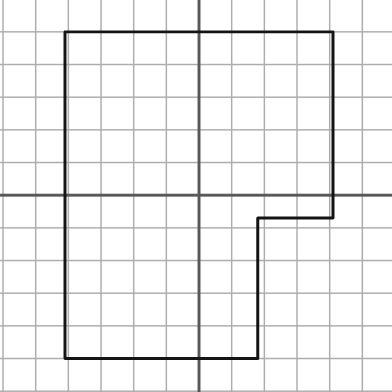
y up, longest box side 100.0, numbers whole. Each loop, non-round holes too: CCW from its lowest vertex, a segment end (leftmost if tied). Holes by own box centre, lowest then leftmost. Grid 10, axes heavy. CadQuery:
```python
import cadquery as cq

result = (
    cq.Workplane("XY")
    .moveTo(-41.0, -50.0)
    .lineTo(18.0, -50.0)
    .lineTo(18.0, -7.0)
    .lineTo(41.0, -7.0)
    .lineTo(41.0, 50.0)
    .lineTo(-41.0, 50.0)
    .close()
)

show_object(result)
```